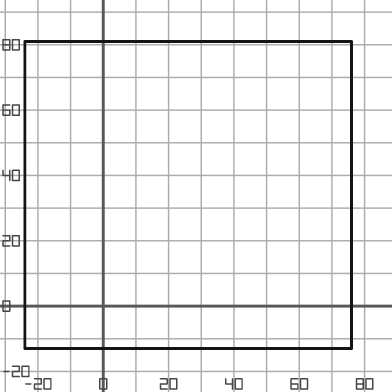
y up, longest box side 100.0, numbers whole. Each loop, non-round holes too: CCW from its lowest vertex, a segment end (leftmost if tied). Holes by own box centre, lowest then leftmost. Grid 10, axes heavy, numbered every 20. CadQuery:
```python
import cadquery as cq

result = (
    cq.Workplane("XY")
    .moveTo(-24.0, -13.0)
    .lineTo(76.0, -13.0)
    .lineTo(76.0, 81.0)
    .lineTo(-24.0, 81.0)
    .close()
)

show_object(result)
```